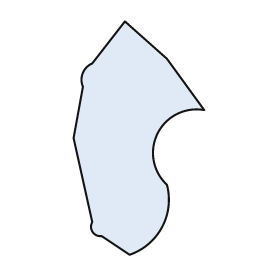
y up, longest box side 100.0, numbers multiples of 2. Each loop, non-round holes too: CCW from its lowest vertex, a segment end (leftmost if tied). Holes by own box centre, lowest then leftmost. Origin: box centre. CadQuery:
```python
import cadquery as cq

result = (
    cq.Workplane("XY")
    .moveTo(-4.0, -50.0)
    .threePointArc((10.0, -38.0), (12.0, -20.0))
    .threePointArc((8.0, 2.0), (28.0, 12.0))
    .lineTo(12.0, 34.0)
    .lineTo(-6.0, 50.0)
    .lineTo(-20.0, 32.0)
    .threePointArc((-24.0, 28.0), (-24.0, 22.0))
    .lineTo(-28.0, 0.0)
    .lineTo(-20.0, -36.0)
    .threePointArc((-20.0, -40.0), (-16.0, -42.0))
    .close()
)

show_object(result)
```